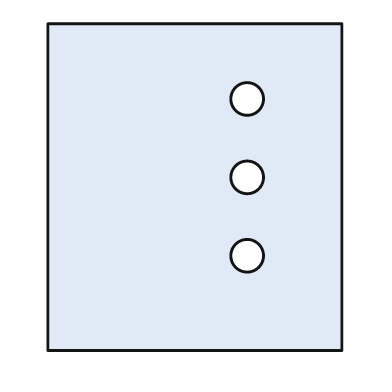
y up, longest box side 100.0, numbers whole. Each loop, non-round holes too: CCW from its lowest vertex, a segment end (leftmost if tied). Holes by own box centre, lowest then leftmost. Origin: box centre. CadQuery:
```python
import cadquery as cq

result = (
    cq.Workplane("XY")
    .moveTo(-45.0, -50.0)
    .lineTo(45.0, -50.0)
    .lineTo(45.0, 50.0)
    .lineTo(-45.0, 50.0)
    .close()
    .moveTo(16.0, -21.0)
    .circle(5.0)
    .moveTo(16.0, 3.0)
    .circle(5.0)
    .moveTo(16.0, 27.0)
    .circle(5.0)
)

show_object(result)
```